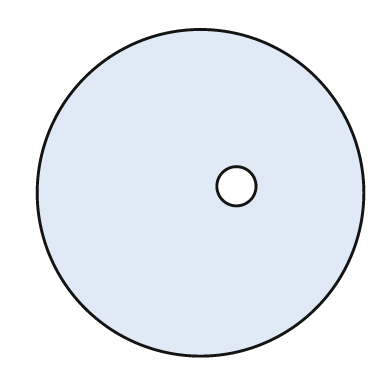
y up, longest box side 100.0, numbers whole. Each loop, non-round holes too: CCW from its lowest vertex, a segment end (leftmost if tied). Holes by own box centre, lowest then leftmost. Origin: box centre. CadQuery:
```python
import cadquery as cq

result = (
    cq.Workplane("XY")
    .moveTo(0.0, 0.0)
    .circle(50.0)
    .moveTo(11.0, 2.0)
    .circle(6.0)
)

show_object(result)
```